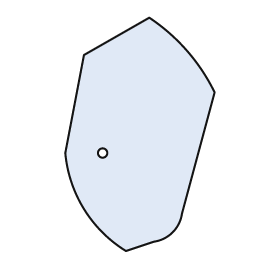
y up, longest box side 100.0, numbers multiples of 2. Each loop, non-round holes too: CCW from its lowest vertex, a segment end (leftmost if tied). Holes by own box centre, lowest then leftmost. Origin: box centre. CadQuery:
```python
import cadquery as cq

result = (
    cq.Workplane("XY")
    .moveTo(-6.0, -50.0)
    .lineTo(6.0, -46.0)
    .threePointArc((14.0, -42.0), (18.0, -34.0))
    .lineTo(32.0, 18.0)
    .threePointArc((20.0, 36.0), (4.0, 50.0))
    .lineTo(-24.0, 34.0)
    .lineTo(-32.0, -8.0)
    .threePointArc((-24.0, -32.0), (-6.0, -50.0))
    .close()
    .moveTo(-16.0, -8.0)
    .circle(2.0)
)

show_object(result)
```